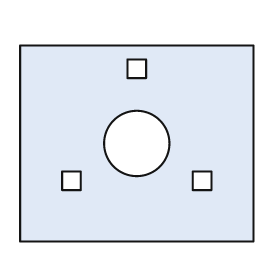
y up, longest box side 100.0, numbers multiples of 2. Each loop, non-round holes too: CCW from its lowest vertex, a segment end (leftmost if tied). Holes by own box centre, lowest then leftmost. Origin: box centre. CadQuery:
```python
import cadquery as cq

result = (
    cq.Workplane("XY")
    .moveTo(-50.0, -42.0)
    .lineTo(50.0, -42.0)
    .lineTo(50.0, 42.0)
    .lineTo(-50.0, 42.0)
    .close()
    .moveTo(-32.0, -20.0)
    .lineTo(-24.0, -20.0)
    .lineTo(-24.0, -12.0)
    .lineTo(-32.0, -12.0)
    .close()
    .moveTo(24.0, -20.0)
    .lineTo(32.0, -20.0)
    .lineTo(32.0, -12.0)
    .lineTo(24.0, -12.0)
    .close()
    .moveTo(0.0, 0.0)
    .circle(14.0)
    .moveTo(-4.0, 28.0)
    .lineTo(4.0, 28.0)
    .lineTo(4.0, 36.0)
    .lineTo(-4.0, 36.0)
    .close()
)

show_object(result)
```